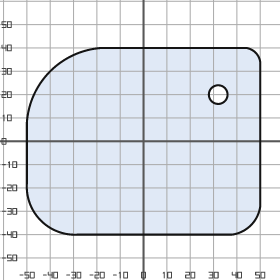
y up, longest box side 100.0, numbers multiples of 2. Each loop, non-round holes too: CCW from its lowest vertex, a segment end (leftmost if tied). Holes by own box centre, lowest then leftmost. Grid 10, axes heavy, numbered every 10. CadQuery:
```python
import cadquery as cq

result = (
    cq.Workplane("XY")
    .moveTo(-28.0, -40.0)
    .lineTo(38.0, -40.0)
    .threePointArc((46.0, -36.0), (50.0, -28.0))
    .lineTo(50.0, 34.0)
    .threePointArc((48.0, 38.0), (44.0, 40.0))
    .lineTo(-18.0, 40.0)
    .threePointArc((-40.0, 30.0), (-50.0, 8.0))
    .lineTo(-50.0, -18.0)
    .threePointArc((-44.0, -34.0), (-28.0, -40.0))
    .close()
    .moveTo(32.0, 20.0)
    .circle(4.0)
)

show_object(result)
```